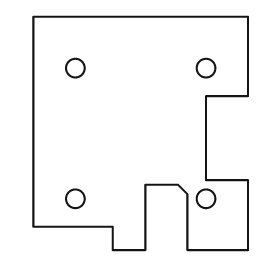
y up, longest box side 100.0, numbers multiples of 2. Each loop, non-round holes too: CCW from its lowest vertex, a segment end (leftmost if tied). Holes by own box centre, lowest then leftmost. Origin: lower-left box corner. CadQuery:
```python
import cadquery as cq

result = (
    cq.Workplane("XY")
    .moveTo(34.0, 0.0)
    .lineTo(48.0, 0.0)
    .lineTo(48.0, 28.0)
    .lineTo(62.0, 28.0)
    .lineTo(66.0, 24.0)
    .lineTo(66.0, 0.0)
    .lineTo(92.0, 0.0)
    .lineTo(92.0, 30.0)
    .lineTo(74.0, 30.0)
    .lineTo(74.0, 66.0)
    .lineTo(92.0, 66.0)
    .lineTo(92.0, 100.0)
    .lineTo(0.0, 100.0)
    .lineTo(0.0, 10.0)
    .lineTo(34.0, 10.0)
    .close()
    .moveTo(18.0, 22.0)
    .circle(4.0)
    .moveTo(74.0, 22.0)
    .circle(4.0)
    .moveTo(18.0, 78.0)
    .circle(4.0)
    .moveTo(74.0, 78.0)
    .circle(4.0)
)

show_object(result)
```